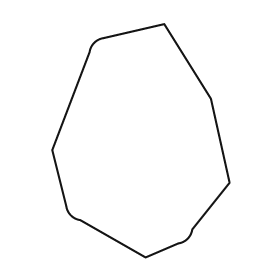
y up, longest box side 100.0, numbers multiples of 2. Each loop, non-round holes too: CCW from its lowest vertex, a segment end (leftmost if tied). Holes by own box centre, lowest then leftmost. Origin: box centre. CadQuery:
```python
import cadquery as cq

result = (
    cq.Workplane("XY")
    .moveTo(2.0, -50.0)
    .lineTo(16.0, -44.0)
    .threePointArc((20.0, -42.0), (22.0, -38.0))
    .lineTo(38.0, -18.0)
    .lineTo(30.0, 18.0)
    .lineTo(10.0, 50.0)
    .lineTo(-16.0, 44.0)
    .threePointArc((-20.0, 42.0), (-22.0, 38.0))
    .lineTo(-38.0, -4.0)
    .lineTo(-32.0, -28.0)
    .threePointArc((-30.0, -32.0), (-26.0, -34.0))
    .close()
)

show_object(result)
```